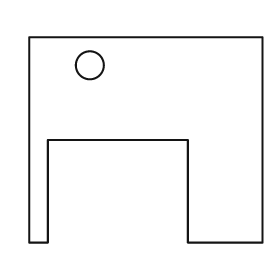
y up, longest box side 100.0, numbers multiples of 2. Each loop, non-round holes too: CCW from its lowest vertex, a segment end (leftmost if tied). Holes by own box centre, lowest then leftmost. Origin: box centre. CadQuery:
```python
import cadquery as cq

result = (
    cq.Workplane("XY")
    .moveTo(-50.0, -44.0)
    .lineTo(-42.0, -44.0)
    .lineTo(-42.0, 0.0)
    .lineTo(18.0, 0.0)
    .lineTo(18.0, -44.0)
    .lineTo(50.0, -44.0)
    .lineTo(50.0, 44.0)
    .lineTo(-50.0, 44.0)
    .close()
    .moveTo(-24.0, 32.0)
    .circle(6.0)
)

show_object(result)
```